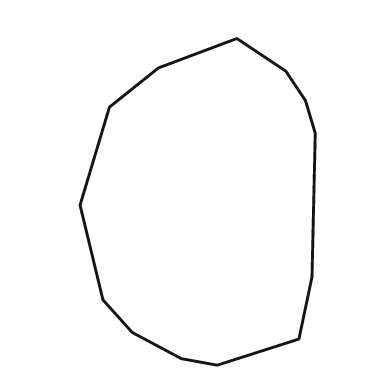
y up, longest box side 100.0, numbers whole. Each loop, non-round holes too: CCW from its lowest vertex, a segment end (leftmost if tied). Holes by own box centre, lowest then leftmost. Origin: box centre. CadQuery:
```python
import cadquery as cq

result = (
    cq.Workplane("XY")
    .moveTo(6.0, -50.0)
    .lineTo(31.0, -42.0)
    .lineTo(35.0, -23.0)
    .lineTo(36.0, 21.0)
    .lineTo(33.0, 31.0)
    .lineTo(27.0, 40.0)
    .lineTo(12.0, 50.0)
    .lineTo(-12.0, 41.0)
    .lineTo(-27.0, 29.0)
    .lineTo(-36.0, -1.0)
    .lineTo(-29.0, -30.0)
    .lineTo(-20.0, -40.0)
    .lineTo(-5.0, -48.0)
    .close()
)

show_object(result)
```